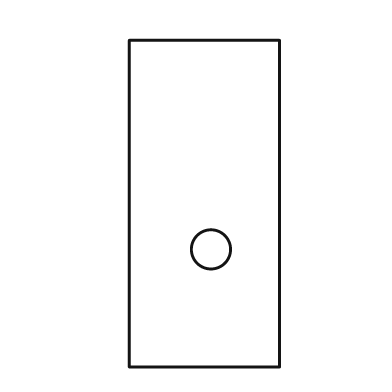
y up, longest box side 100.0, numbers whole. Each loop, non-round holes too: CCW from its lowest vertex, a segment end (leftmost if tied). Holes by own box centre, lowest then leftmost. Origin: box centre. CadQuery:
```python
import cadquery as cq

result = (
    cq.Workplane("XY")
    .moveTo(-23.0, -50.0)
    .lineTo(23.0, -50.0)
    .lineTo(23.0, 50.0)
    .lineTo(-23.0, 50.0)
    .close()
    .moveTo(2.0, -14.0)
    .circle(6.0)
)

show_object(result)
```